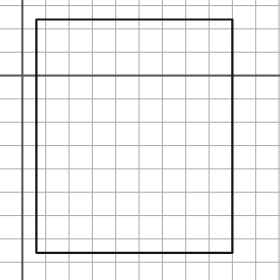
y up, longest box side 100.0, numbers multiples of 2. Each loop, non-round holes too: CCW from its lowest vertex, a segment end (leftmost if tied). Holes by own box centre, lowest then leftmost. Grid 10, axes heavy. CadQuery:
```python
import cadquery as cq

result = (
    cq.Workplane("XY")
    .moveTo(6.0, -76.0)
    .lineTo(90.0, -76.0)
    .lineTo(90.0, 24.0)
    .lineTo(6.0, 24.0)
    .close()
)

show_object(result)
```